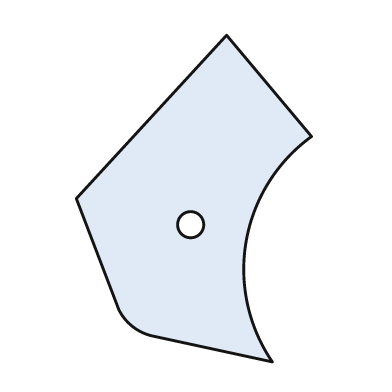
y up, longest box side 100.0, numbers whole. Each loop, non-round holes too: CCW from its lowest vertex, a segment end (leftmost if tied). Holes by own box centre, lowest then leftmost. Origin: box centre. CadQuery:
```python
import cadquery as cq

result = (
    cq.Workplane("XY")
    .moveTo(24.0, -50.0)
    .threePointArc((16.0, -13.0), (36.0, 19.0))
    .lineTo(10.0, 50.0)
    .lineTo(-36.0, 0.0)
    .lineTo(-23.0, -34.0)
    .threePointArc((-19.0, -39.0), (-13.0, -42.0))
    .close()
    .moveTo(-1.0, -8.0)
    .circle(4.0)
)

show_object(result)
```